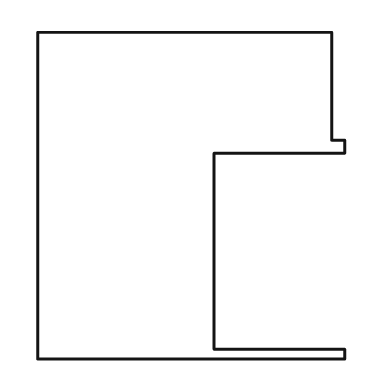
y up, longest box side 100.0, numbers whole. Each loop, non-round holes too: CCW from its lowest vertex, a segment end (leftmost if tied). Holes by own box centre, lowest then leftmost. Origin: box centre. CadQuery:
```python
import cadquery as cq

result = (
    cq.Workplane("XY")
    .moveTo(-47.0, -50.0)
    .lineTo(47.0, -50.0)
    .lineTo(47.0, -47.0)
    .lineTo(7.0, -47.0)
    .lineTo(7.0, 13.0)
    .lineTo(47.0, 13.0)
    .lineTo(47.0, 17.0)
    .lineTo(43.0, 17.0)
    .lineTo(43.0, 50.0)
    .lineTo(-47.0, 50.0)
    .close()
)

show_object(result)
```